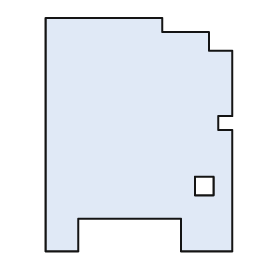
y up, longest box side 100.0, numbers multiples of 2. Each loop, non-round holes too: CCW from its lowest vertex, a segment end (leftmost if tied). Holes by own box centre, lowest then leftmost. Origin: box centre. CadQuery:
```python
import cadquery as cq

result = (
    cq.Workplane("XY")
    .moveTo(-40.0, -50.0)
    .lineTo(-26.0, -50.0)
    .lineTo(-26.0, -36.0)
    .lineTo(18.0, -36.0)
    .lineTo(18.0, -50.0)
    .lineTo(40.0, -50.0)
    .lineTo(40.0, 2.0)
    .lineTo(34.0, 2.0)
    .lineTo(34.0, 8.0)
    .lineTo(40.0, 8.0)
    .lineTo(40.0, 36.0)
    .lineTo(30.0, 36.0)
    .lineTo(30.0, 44.0)
    .lineTo(10.0, 44.0)
    .lineTo(10.0, 50.0)
    .lineTo(-40.0, 50.0)
    .close()
    .moveTo(24.0, -26.0)
    .lineTo(32.0, -26.0)
    .lineTo(32.0, -18.0)
    .lineTo(24.0, -18.0)
    .close()
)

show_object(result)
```